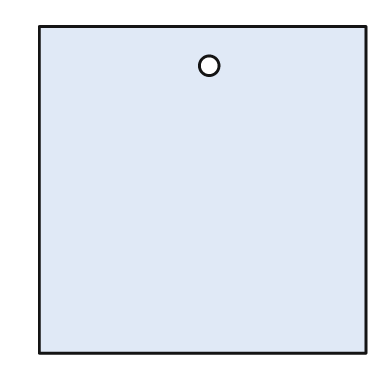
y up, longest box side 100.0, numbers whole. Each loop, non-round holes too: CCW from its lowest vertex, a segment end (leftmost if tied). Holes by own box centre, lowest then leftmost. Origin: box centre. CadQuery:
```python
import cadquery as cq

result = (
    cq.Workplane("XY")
    .moveTo(-50.0, -50.0)
    .lineTo(50.0, -50.0)
    .lineTo(50.0, 50.0)
    .lineTo(-50.0, 50.0)
    .close()
    .moveTo(2.0, 38.0)
    .circle(3.0)
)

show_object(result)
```